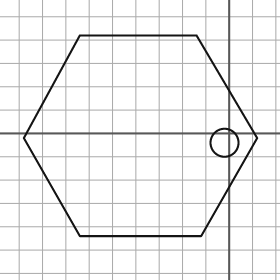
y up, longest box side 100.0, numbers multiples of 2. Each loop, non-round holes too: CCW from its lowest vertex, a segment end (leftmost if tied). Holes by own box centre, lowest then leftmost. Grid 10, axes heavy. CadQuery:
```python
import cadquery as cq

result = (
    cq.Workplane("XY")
    .moveTo(-64.0, -44.0)
    .lineTo(-12.0, -44.0)
    .lineTo(12.0, -2.0)
    .lineTo(-14.0, 42.0)
    .lineTo(-64.0, 42.0)
    .lineTo(-88.0, -2.0)
    .close()
    .moveTo(-2.0, -4.0)
    .circle(6.0)
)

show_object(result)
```